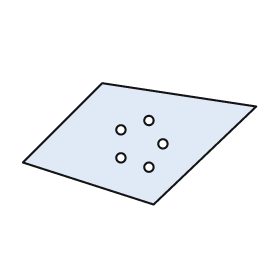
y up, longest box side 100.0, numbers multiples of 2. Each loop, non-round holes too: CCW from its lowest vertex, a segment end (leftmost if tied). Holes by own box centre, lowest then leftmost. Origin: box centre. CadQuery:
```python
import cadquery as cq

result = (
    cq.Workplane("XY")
    .moveTo(6.0, -26.0)
    .lineTo(50.0, 16.0)
    .lineTo(-16.0, 26.0)
    .lineTo(-50.0, -8.0)
    .close()
    .moveTo(4.0, -10.0)
    .circle(2.0)
    .moveTo(-8.0, -6.0)
    .circle(2.0)
    .moveTo(10.0, 0.0)
    .circle(2.0)
    .moveTo(-8.0, 6.0)
    .circle(2.0)
    .moveTo(4.0, 10.0)
    .circle(2.0)
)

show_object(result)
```